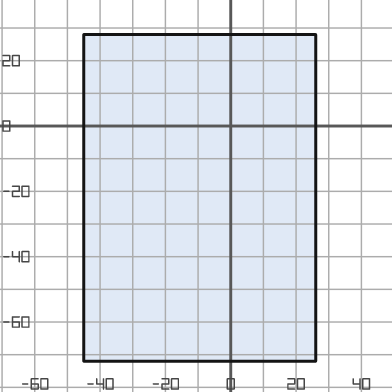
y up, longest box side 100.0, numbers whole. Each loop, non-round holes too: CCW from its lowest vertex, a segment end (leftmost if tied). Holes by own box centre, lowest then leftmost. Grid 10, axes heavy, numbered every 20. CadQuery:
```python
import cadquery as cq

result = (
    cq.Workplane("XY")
    .moveTo(-45.0, -72.0)
    .lineTo(26.0, -72.0)
    .lineTo(26.0, 28.0)
    .lineTo(-45.0, 28.0)
    .close()
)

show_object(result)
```